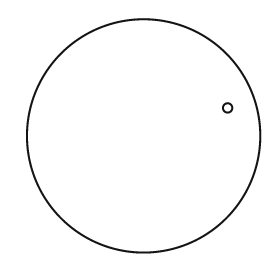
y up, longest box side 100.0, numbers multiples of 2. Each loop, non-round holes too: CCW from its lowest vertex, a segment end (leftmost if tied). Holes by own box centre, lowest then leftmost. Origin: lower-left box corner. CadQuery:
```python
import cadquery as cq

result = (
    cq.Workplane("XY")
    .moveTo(50.0, 50.0)
    .circle(50.0)
    .moveTo(86.0, 62.0)
    .circle(2.0)
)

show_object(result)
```